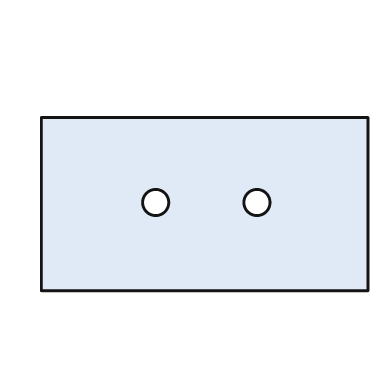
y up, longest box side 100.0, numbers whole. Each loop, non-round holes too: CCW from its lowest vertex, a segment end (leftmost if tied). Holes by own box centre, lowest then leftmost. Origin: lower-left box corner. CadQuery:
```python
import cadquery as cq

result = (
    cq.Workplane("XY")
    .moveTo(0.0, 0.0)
    .lineTo(100.0, 0.0)
    .lineTo(100.0, 53.0)
    .lineTo(0.0, 53.0)
    .close()
    .moveTo(35.0, 27.0)
    .circle(4.0)
    .moveTo(66.0, 27.0)
    .circle(4.0)
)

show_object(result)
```